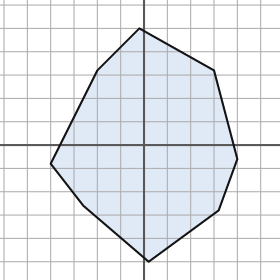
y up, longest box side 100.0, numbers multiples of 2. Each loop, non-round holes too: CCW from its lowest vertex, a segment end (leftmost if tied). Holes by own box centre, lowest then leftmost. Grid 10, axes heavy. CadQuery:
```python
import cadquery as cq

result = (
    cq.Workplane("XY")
    .moveTo(2.0, -50.0)
    .lineTo(32.0, -28.0)
    .lineTo(40.0, -6.0)
    .lineTo(30.0, 32.0)
    .lineTo(-2.0, 50.0)
    .lineTo(-20.0, 32.0)
    .lineTo(-40.0, -8.0)
    .lineTo(-26.0, -26.0)
    .close()
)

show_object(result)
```